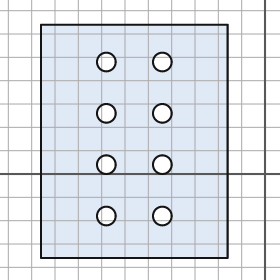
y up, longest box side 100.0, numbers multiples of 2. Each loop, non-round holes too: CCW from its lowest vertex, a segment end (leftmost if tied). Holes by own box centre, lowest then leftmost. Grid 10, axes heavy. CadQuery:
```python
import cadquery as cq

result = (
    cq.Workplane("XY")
    .moveTo(-96.0, -36.0)
    .lineTo(-16.0, -36.0)
    .lineTo(-16.0, 64.0)
    .lineTo(-96.0, 64.0)
    .close()
    .moveTo(-68.0, -18.0)
    .circle(4.0)
    .moveTo(-44.0, -18.0)
    .circle(4.0)
    .moveTo(-68.0, 4.0)
    .circle(4.0)
    .moveTo(-44.0, 4.0)
    .circle(4.0)
    .moveTo(-68.0, 26.0)
    .circle(4.0)
    .moveTo(-44.0, 26.0)
    .circle(4.0)
    .moveTo(-68.0, 48.0)
    .circle(4.0)
    .moveTo(-44.0, 48.0)
    .circle(4.0)
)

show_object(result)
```